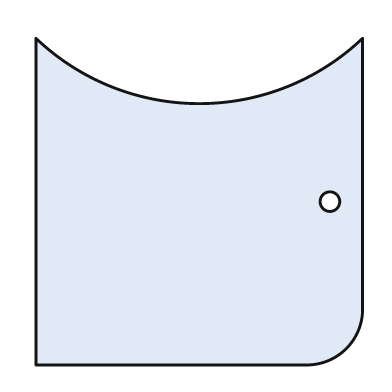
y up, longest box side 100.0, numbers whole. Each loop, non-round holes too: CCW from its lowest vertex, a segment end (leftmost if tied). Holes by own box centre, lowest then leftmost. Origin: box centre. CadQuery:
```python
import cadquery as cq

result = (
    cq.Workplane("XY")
    .moveTo(-50.0, -50.0)
    .lineTo(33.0, -50.0)
    .threePointArc((45.0, -45.0), (50.0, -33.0))
    .lineTo(50.0, 50.0)
    .threePointArc((0.0, 30.0), (-50.0, 50.0))
    .close()
    .moveTo(40.0, 0.0)
    .circle(3.0)
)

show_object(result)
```